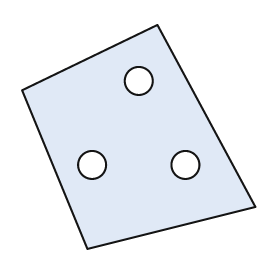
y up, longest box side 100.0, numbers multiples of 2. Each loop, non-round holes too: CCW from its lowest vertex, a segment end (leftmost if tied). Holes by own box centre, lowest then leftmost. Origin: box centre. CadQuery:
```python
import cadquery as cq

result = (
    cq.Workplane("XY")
    .moveTo(-22.0, -48.0)
    .lineTo(50.0, -30.0)
    .lineTo(8.0, 48.0)
    .lineTo(-50.0, 20.0)
    .close()
    .moveTo(-20.0, -12.0)
    .circle(6.0)
    .moveTo(20.0, -12.0)
    .circle(6.0)
    .moveTo(0.0, 24.0)
    .circle(6.0)
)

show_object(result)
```